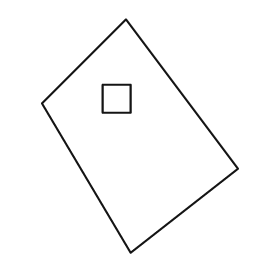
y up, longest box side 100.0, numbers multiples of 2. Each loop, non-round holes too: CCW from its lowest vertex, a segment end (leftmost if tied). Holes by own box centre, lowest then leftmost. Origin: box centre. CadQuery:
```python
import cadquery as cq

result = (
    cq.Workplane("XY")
    .moveTo(-4.0, -50.0)
    .lineTo(42.0, -14.0)
    .lineTo(-6.0, 50.0)
    .lineTo(-42.0, 14.0)
    .close()
    .moveTo(-16.0, 10.0)
    .lineTo(-4.0, 10.0)
    .lineTo(-4.0, 22.0)
    .lineTo(-16.0, 22.0)
    .close()
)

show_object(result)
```